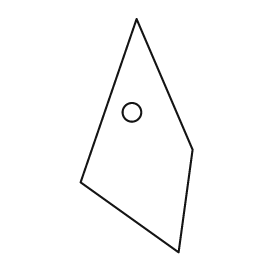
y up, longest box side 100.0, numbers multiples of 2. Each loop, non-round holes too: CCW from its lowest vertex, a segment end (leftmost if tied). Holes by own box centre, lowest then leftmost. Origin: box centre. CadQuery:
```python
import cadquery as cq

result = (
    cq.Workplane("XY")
    .moveTo(18.0, -50.0)
    .lineTo(24.0, -6.0)
    .lineTo(0.0, 50.0)
    .lineTo(-24.0, -20.0)
    .close()
    .moveTo(-2.0, 10.0)
    .circle(4.0)
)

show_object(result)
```